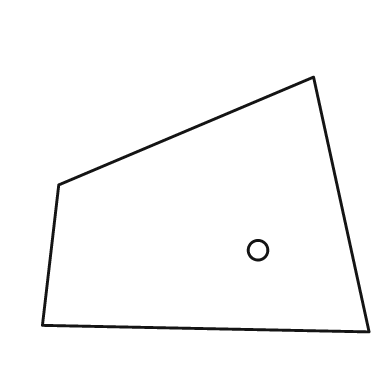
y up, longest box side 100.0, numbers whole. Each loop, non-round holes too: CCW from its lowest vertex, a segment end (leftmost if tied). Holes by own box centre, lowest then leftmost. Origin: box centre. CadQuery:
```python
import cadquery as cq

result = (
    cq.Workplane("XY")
    .moveTo(50.0, -39.0)
    .lineTo(33.0, 39.0)
    .lineTo(-45.0, 6.0)
    .lineTo(-50.0, -37.0)
    .close()
    .moveTo(16.0, -14.0)
    .circle(3.0)
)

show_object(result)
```